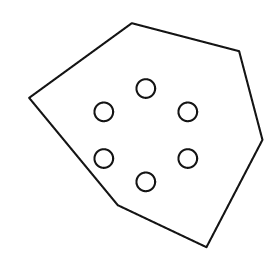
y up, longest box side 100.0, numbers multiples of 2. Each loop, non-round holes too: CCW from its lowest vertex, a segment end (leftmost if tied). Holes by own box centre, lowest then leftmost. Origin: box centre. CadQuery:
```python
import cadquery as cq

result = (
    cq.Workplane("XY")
    .moveTo(26.0, -48.0)
    .lineTo(50.0, -2.0)
    .lineTo(40.0, 36.0)
    .lineTo(-6.0, 48.0)
    .lineTo(-50.0, 16.0)
    .lineTo(-12.0, -30.0)
    .close()
    .moveTo(0.0, -20.0)
    .circle(4.0)
    .moveTo(-18.0, -10.0)
    .circle(4.0)
    .moveTo(18.0, -10.0)
    .circle(4.0)
    .moveTo(-18.0, 10.0)
    .circle(4.0)
    .moveTo(18.0, 10.0)
    .circle(4.0)
    .moveTo(0.0, 20.0)
    .circle(4.0)
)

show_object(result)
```